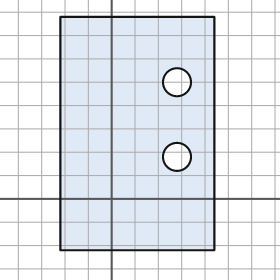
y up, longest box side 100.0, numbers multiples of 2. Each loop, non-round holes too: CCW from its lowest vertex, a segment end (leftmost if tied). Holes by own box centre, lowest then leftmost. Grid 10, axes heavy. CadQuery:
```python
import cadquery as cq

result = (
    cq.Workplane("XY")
    .moveTo(-22.0, -22.0)
    .lineTo(44.0, -22.0)
    .lineTo(44.0, 78.0)
    .lineTo(-22.0, 78.0)
    .close()
    .moveTo(28.0, 18.0)
    .circle(6.0)
    .moveTo(28.0, 50.0)
    .circle(6.0)
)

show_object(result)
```